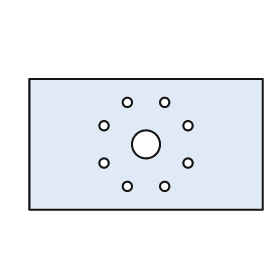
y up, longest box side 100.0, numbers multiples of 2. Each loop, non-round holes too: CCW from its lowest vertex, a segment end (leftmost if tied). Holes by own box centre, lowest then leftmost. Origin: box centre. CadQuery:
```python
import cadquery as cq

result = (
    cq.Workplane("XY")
    .moveTo(-50.0, -28.0)
    .lineTo(50.0, -28.0)
    .lineTo(50.0, 28.0)
    .lineTo(-50.0, 28.0)
    .close()
    .moveTo(-8.0, -18.0)
    .circle(2.0)
    .moveTo(8.0, -18.0)
    .circle(2.0)
    .moveTo(-18.0, -8.0)
    .circle(2.0)
    .moveTo(18.0, -8.0)
    .circle(2.0)
    .moveTo(0.0, 0.0)
    .circle(6.0)
    .moveTo(-18.0, 8.0)
    .circle(2.0)
    .moveTo(18.0, 8.0)
    .circle(2.0)
    .moveTo(-8.0, 18.0)
    .circle(2.0)
    .moveTo(8.0, 18.0)
    .circle(2.0)
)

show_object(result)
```